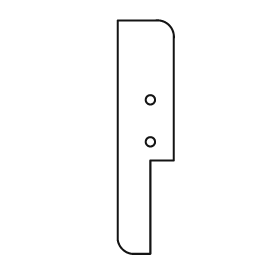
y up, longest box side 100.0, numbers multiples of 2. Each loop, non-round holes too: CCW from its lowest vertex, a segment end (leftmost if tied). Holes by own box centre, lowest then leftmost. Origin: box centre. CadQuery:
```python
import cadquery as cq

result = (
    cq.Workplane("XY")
    .moveTo(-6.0, -50.0)
    .lineTo(2.0, -50.0)
    .lineTo(2.0, -10.0)
    .lineTo(12.0, -10.0)
    .lineTo(12.0, 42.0)
    .threePointArc((10.0, 48.0), (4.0, 50.0))
    .lineTo(-12.0, 50.0)
    .lineTo(-12.0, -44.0)
    .threePointArc((-10.0, -48.0), (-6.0, -50.0))
    .close()
    .moveTo(2.0, -2.0)
    .circle(2.0)
    .moveTo(2.0, 16.0)
    .circle(2.0)
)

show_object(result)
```